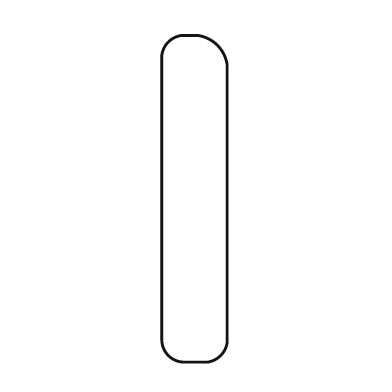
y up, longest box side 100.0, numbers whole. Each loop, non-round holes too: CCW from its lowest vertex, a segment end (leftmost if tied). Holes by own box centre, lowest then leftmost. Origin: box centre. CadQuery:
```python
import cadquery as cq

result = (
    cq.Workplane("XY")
    .moveTo(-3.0, -50.0)
    .lineTo(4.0, -50.0)
    .threePointArc((8.0, -48.0), (10.0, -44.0))
    .lineTo(10.0, 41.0)
    .threePointArc((7.0, 47.0), (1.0, 50.0))
    .lineTo(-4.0, 50.0)
    .threePointArc((-8.0, 48.0), (-10.0, 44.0))
    .lineTo(-10.0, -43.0)
    .threePointArc((-8.0, -48.0), (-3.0, -50.0))
    .close()
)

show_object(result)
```